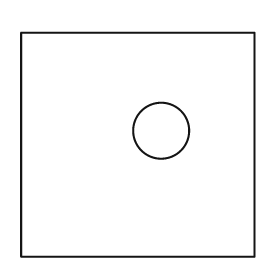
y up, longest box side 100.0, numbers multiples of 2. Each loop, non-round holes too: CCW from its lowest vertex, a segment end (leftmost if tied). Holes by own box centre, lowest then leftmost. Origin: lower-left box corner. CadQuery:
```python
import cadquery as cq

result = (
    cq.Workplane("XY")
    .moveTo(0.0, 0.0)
    .lineTo(100.0, 0.0)
    .lineTo(100.0, 96.0)
    .lineTo(0.0, 96.0)
    .close()
    .moveTo(60.0, 54.0)
    .circle(12.0)
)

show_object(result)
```